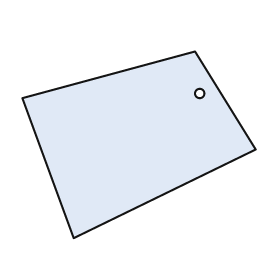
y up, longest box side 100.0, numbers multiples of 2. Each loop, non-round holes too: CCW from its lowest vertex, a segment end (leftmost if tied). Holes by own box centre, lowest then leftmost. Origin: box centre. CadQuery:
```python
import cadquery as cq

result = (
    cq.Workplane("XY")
    .moveTo(-28.0, -40.0)
    .lineTo(50.0, -2.0)
    .lineTo(24.0, 40.0)
    .lineTo(-50.0, 20.0)
    .close()
    .moveTo(26.0, 22.0)
    .circle(2.0)
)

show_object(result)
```